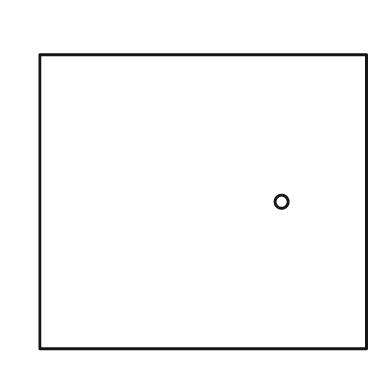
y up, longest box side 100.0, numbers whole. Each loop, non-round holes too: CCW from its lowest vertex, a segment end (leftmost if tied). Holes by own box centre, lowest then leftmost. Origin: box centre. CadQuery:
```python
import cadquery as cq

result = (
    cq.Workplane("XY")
    .moveTo(-50.0, -45.0)
    .lineTo(50.0, -45.0)
    .lineTo(50.0, 45.0)
    .lineTo(-50.0, 45.0)
    .close()
    .moveTo(24.0, 0.0)
    .circle(2.0)
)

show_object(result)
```